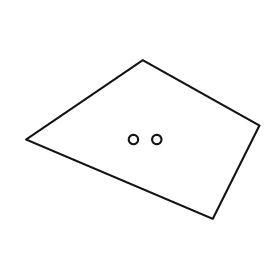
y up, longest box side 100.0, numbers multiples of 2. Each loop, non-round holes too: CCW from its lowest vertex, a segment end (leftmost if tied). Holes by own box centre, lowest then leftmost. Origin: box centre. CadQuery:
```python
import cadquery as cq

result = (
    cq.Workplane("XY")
    .moveTo(30.0, -34.0)
    .lineTo(50.0, 6.0)
    .lineTo(0.0, 34.0)
    .lineTo(-50.0, 0.0)
    .close()
    .moveTo(-4.0, 0.0)
    .circle(2.0)
    .moveTo(6.0, 0.0)
    .circle(2.0)
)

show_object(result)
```